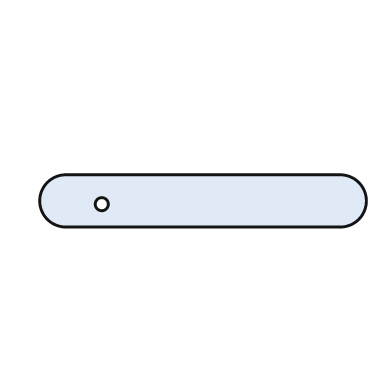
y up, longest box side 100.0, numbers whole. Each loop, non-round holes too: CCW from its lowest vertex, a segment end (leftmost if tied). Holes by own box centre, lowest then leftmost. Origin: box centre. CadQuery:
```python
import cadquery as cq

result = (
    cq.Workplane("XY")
    .moveTo(-42.0, -8.0)
    .lineTo(42.0, -8.0)
    .threePointArc((50.0, 0.0), (42.0, 8.0))
    .lineTo(-42.0, 8.0)
    .threePointArc((-50.0, 0.0), (-42.0, -8.0))
    .close()
    .moveTo(-31.0, -1.0)
    .circle(2.0)
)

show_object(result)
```